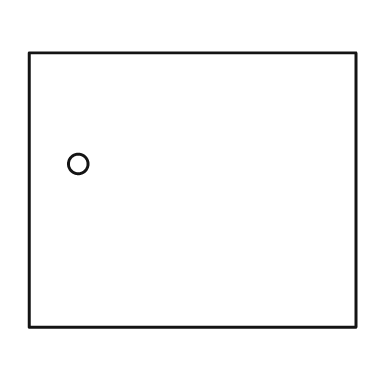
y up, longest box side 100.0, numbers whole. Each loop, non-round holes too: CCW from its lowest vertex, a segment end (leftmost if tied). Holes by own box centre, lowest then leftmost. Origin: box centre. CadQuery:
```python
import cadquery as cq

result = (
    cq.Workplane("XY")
    .moveTo(-50.0, -42.0)
    .lineTo(50.0, -42.0)
    .lineTo(50.0, 42.0)
    .lineTo(-50.0, 42.0)
    .close()
    .moveTo(-35.0, 8.0)
    .circle(3.0)
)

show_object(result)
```